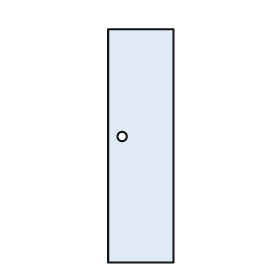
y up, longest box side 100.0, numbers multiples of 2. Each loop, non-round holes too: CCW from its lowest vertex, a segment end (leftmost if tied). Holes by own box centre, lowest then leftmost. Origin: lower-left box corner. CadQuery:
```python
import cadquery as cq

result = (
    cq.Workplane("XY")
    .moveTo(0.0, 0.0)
    .lineTo(28.0, 0.0)
    .lineTo(28.0, 100.0)
    .lineTo(0.0, 100.0)
    .close()
    .moveTo(6.0, 54.0)
    .circle(2.0)
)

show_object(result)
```